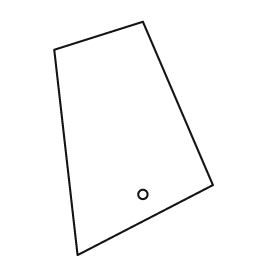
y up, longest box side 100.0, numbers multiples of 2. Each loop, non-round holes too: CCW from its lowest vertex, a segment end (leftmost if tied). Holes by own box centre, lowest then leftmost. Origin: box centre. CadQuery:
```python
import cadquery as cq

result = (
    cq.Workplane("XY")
    .moveTo(-24.0, -50.0)
    .lineTo(34.0, -20.0)
    .lineTo(4.0, 50.0)
    .lineTo(-34.0, 38.0)
    .close()
    .moveTo(4.0, -24.0)
    .circle(2.0)
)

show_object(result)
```